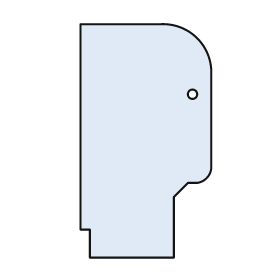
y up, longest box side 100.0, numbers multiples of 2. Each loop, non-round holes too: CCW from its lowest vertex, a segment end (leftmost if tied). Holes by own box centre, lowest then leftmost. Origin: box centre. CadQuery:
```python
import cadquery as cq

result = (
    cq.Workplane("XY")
    .moveTo(-24.0, -50.0)
    .lineTo(12.0, -50.0)
    .lineTo(12.0, -24.0)
    .lineTo(18.0, -18.0)
    .lineTo(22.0, -18.0)
    .threePointArc((26.0, -16.0), (28.0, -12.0))
    .lineTo(28.0, 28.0)
    .threePointArc((22.0, 44.0), (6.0, 50.0))
    .lineTo(-28.0, 50.0)
    .lineTo(-28.0, -38.0)
    .lineTo(-24.0, -38.0)
    .close()
    .moveTo(20.0, 20.0)
    .circle(2.0)
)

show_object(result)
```